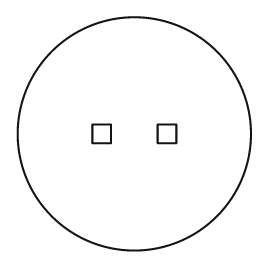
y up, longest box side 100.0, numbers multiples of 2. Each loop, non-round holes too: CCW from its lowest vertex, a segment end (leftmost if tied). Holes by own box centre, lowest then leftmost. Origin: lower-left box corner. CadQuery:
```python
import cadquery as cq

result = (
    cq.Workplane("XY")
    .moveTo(50.0, 50.0)
    .circle(50.0)
    .moveTo(32.0, 46.0)
    .lineTo(40.0, 46.0)
    .lineTo(40.0, 54.0)
    .lineTo(32.0, 54.0)
    .close()
    .moveTo(60.0, 46.0)
    .lineTo(68.0, 46.0)
    .lineTo(68.0, 54.0)
    .lineTo(60.0, 54.0)
    .close()
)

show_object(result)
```